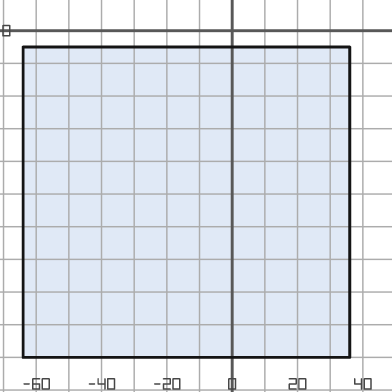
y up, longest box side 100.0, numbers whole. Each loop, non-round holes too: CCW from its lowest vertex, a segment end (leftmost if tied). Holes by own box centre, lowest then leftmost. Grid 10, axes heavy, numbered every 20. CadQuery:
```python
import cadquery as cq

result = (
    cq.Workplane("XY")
    .moveTo(-64.0, -100.0)
    .lineTo(36.0, -100.0)
    .lineTo(36.0, -5.0)
    .lineTo(-64.0, -5.0)
    .close()
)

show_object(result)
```